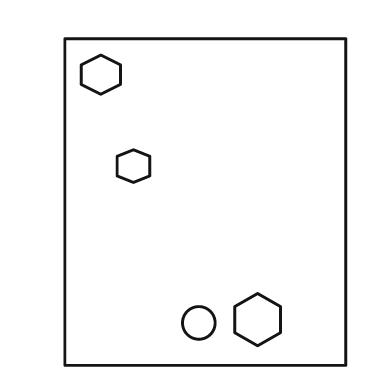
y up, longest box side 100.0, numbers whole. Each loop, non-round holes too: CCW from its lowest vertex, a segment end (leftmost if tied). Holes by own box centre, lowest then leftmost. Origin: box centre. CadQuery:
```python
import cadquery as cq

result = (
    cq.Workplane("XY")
    .moveTo(-43.0, -50.0)
    .lineTo(43.0, -50.0)
    .lineTo(43.0, 50.0)
    .lineTo(-43.0, 50.0)
    .close()
    .moveTo(-2.0, -37.0)
    .circle(5.0)
    .moveTo(16.0, -44.0)
    .lineTo(23.0, -40.0)
    .lineTo(23.0, -32.0)
    .lineTo(16.0, -28.0)
    .lineTo(9.0, -32.0)
    .lineTo(9.0, -40.0)
    .close()
    .moveTo(-22.0, 6.0)
    .lineTo(-17.0, 8.0)
    .lineTo(-17.0, 14.0)
    .lineTo(-22.0, 16.0)
    .lineTo(-27.0, 14.0)
    .lineTo(-27.0, 8.0)
    .close()
    .moveTo(-32.0, 33.0)
    .lineTo(-26.0, 36.0)
    .lineTo(-26.0, 42.0)
    .lineTo(-32.0, 45.0)
    .lineTo(-38.0, 42.0)
    .lineTo(-38.0, 36.0)
    .close()
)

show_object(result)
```